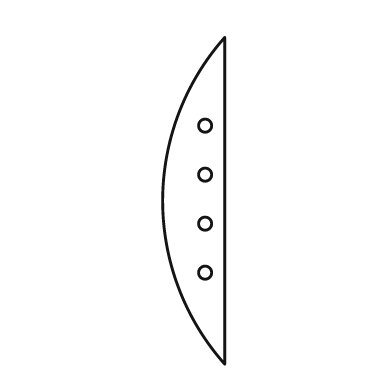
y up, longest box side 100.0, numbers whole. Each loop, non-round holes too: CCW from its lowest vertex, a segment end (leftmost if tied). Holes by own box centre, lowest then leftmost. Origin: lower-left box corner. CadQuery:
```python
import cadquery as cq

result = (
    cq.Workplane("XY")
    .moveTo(19.0, 0.0)
    .lineTo(19.0, 100.0)
    .threePointArc((0.0, 50.0), (19.0, 0.0))
    .close()
    .moveTo(13.0, 28.0)
    .circle(2.0)
    .moveTo(13.0, 43.0)
    .circle(2.0)
    .moveTo(13.0, 58.0)
    .circle(2.0)
    .moveTo(13.0, 73.0)
    .circle(2.0)
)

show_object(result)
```